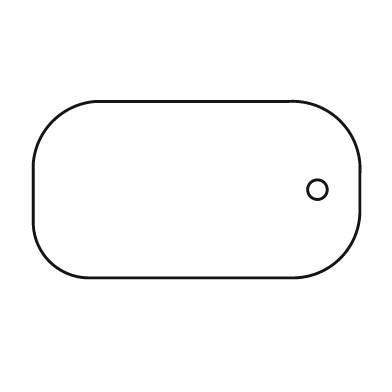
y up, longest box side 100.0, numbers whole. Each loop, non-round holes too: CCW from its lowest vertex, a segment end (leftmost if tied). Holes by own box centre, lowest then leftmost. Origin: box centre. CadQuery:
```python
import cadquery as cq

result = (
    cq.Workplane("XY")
    .moveTo(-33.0, -27.0)
    .lineTo(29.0, -27.0)
    .threePointArc((44.0, -21.0), (50.0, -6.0))
    .lineTo(50.0, 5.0)
    .threePointArc((44.0, 21.0), (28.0, 27.0))
    .lineTo(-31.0, 27.0)
    .threePointArc((-44.0, 21.0), (-50.0, 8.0))
    .lineTo(-50.0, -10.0)
    .threePointArc((-45.0, -22.0), (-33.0, -27.0))
    .close()
    .moveTo(37.0, 0.0)
    .circle(3.0)
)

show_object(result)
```